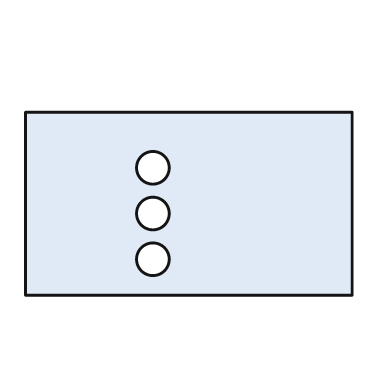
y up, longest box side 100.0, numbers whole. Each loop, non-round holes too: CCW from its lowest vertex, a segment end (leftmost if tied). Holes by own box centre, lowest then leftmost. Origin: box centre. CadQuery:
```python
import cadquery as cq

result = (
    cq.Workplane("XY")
    .moveTo(-50.0, -28.0)
    .lineTo(50.0, -28.0)
    .lineTo(50.0, 28.0)
    .lineTo(-50.0, 28.0)
    .close()
    .moveTo(-11.0, -17.0)
    .circle(5.0)
    .moveTo(-11.0, -3.0)
    .circle(5.0)
    .moveTo(-11.0, 11.0)
    .circle(5.0)
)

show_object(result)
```